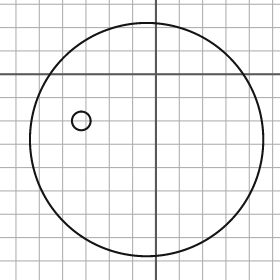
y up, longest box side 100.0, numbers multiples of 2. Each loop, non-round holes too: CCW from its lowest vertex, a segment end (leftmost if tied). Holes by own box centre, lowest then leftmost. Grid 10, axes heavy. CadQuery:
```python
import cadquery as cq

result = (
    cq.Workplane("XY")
    .moveTo(-4.0, -28.0)
    .circle(50.0)
    .moveTo(-32.0, -20.0)
    .circle(4.0)
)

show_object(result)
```